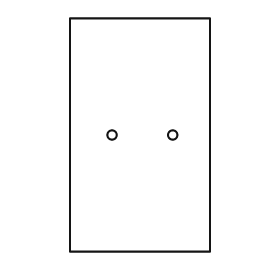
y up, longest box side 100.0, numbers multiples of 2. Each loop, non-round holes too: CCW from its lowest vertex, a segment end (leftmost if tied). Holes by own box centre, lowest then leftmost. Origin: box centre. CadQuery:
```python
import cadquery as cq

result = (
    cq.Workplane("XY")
    .moveTo(-30.0, -50.0)
    .lineTo(30.0, -50.0)
    .lineTo(30.0, 50.0)
    .lineTo(-30.0, 50.0)
    .close()
    .moveTo(-12.0, 0.0)
    .circle(2.0)
    .moveTo(14.0, 0.0)
    .circle(2.0)
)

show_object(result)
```